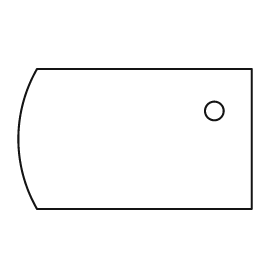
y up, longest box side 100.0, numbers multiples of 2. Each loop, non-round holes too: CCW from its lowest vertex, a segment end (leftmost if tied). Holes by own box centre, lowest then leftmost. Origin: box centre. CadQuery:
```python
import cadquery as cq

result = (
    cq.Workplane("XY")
    .moveTo(-42.0, -30.0)
    .lineTo(50.0, -30.0)
    .lineTo(50.0, 30.0)
    .lineTo(-42.0, 30.0)
    .threePointArc((-50.0, 0.0), (-42.0, -30.0))
    .close()
    .moveTo(34.0, 12.0)
    .circle(4.0)
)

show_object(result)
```